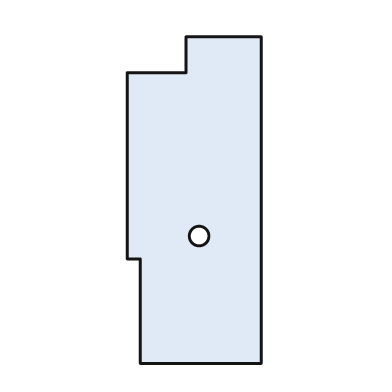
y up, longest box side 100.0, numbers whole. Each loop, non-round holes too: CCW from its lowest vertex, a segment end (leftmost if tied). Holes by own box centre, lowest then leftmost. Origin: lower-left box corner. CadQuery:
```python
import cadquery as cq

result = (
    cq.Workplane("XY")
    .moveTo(4.0, 0.0)
    .lineTo(41.0, 0.0)
    .lineTo(41.0, 100.0)
    .lineTo(18.0, 100.0)
    .lineTo(18.0, 89.0)
    .lineTo(0.0, 89.0)
    .lineTo(0.0, 32.0)
    .lineTo(4.0, 32.0)
    .close()
    .moveTo(22.0, 39.0)
    .circle(3.0)
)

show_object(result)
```